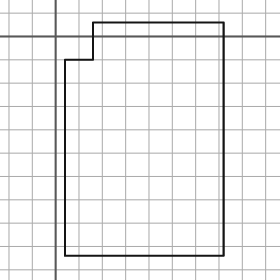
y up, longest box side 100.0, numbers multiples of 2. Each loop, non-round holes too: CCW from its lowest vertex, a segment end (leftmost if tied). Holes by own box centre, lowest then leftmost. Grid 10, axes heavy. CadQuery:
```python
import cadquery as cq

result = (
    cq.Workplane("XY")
    .moveTo(4.0, -94.0)
    .lineTo(72.0, -94.0)
    .lineTo(72.0, 6.0)
    .lineTo(16.0, 6.0)
    .lineTo(16.0, -10.0)
    .lineTo(4.0, -10.0)
    .close()
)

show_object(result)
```